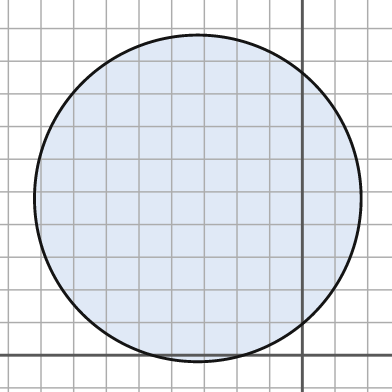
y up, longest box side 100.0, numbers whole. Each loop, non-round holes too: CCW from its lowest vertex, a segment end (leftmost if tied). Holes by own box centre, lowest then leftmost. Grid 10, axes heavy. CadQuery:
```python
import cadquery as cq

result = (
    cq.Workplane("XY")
    .moveTo(-32.0, 48.0)
    .circle(50.0)
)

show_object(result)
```